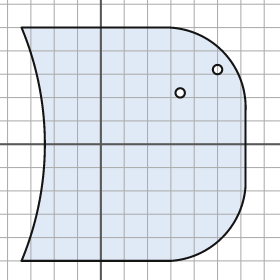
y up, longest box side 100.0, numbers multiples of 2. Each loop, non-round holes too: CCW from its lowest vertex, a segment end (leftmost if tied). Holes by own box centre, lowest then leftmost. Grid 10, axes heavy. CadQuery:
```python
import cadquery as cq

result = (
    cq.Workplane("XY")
    .moveTo(-34.0, -50.0)
    .lineTo(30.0, -50.0)
    .threePointArc((52.0, -40.0), (62.0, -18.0))
    .lineTo(62.0, 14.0)
    .threePointArc((52.0, 40.0), (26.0, 50.0))
    .lineTo(-34.0, 50.0)
    .threePointArc((-24.0, 0.0), (-34.0, -50.0))
    .close()
    .moveTo(34.0, 22.0)
    .circle(2.0)
    .moveTo(50.0, 32.0)
    .circle(2.0)
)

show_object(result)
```